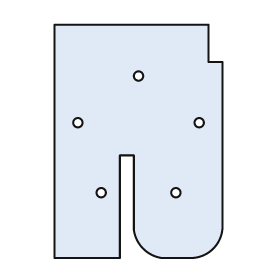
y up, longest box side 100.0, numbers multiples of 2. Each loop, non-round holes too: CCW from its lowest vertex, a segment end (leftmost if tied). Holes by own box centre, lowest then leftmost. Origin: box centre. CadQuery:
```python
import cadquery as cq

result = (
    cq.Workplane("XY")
    .moveTo(-36.0, -50.0)
    .lineTo(-8.0, -50.0)
    .lineTo(-8.0, -6.0)
    .lineTo(-2.0, -6.0)
    .lineTo(-2.0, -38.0)
    .threePointArc((2.0, -46.0), (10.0, -50.0))
    .lineTo(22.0, -50.0)
    .threePointArc((32.0, -46.0), (36.0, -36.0))
    .lineTo(36.0, 34.0)
    .lineTo(30.0, 34.0)
    .lineTo(30.0, 50.0)
    .lineTo(-36.0, 50.0)
    .close()
    .moveTo(-16.0, -22.0)
    .circle(2.0)
    .moveTo(16.0, -22.0)
    .circle(2.0)
    .moveTo(-26.0, 8.0)
    .circle(2.0)
    .moveTo(26.0, 8.0)
    .circle(2.0)
    .moveTo(0.0, 28.0)
    .circle(2.0)
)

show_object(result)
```